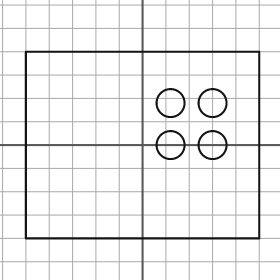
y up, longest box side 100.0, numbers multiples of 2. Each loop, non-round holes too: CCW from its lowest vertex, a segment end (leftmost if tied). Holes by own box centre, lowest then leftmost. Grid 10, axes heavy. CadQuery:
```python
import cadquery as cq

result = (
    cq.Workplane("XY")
    .moveTo(-50.0, -40.0)
    .lineTo(50.0, -40.0)
    .lineTo(50.0, 40.0)
    .lineTo(-50.0, 40.0)
    .close()
    .moveTo(12.0, 0.0)
    .circle(6.0)
    .moveTo(30.0, 0.0)
    .circle(6.0)
    .moveTo(12.0, 18.0)
    .circle(6.0)
    .moveTo(30.0, 18.0)
    .circle(6.0)
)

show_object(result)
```